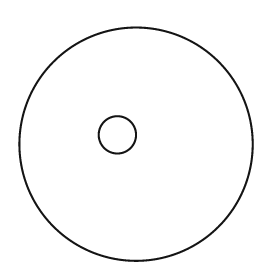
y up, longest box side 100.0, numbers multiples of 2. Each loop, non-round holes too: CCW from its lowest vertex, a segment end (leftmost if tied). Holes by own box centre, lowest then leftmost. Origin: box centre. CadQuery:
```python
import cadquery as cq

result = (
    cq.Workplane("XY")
    .moveTo(0.0, 0.0)
    .circle(50.0)
    .moveTo(-8.0, 4.0)
    .circle(8.0)
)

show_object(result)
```